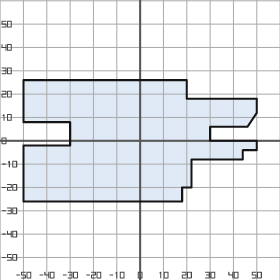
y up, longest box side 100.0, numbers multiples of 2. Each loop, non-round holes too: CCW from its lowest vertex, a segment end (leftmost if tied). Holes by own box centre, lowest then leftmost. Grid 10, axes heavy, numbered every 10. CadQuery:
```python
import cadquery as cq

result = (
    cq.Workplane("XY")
    .moveTo(-50.0, -26.0)
    .lineTo(18.0, -26.0)
    .lineTo(18.0, -20.0)
    .lineTo(22.0, -20.0)
    .lineTo(22.0, -8.0)
    .lineTo(44.0, -8.0)
    .lineTo(44.0, -4.0)
    .lineTo(50.0, -4.0)
    .lineTo(50.0, 0.0)
    .lineTo(30.0, 0.0)
    .lineTo(30.0, 6.0)
    .lineTo(46.0, 6.0)
    .lineTo(50.0, 12.0)
    .lineTo(50.0, 18.0)
    .lineTo(20.0, 18.0)
    .lineTo(20.0, 26.0)
    .lineTo(-50.0, 26.0)
    .lineTo(-50.0, 8.0)
    .lineTo(-30.0, 8.0)
    .lineTo(-30.0, -2.0)
    .lineTo(-50.0, -2.0)
    .close()
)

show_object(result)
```